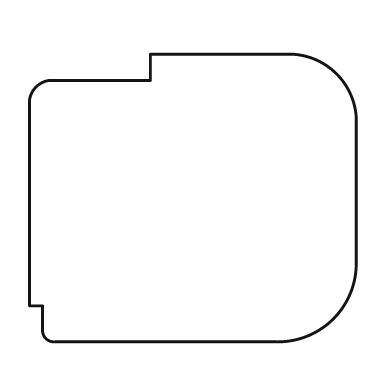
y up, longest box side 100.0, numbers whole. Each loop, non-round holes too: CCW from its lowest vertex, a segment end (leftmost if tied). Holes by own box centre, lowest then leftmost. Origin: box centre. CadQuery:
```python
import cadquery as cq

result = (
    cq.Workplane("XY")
    .moveTo(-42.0, -44.0)
    .lineTo(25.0, -44.0)
    .threePointArc((43.0, -37.0), (50.0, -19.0))
    .lineTo(50.0, 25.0)
    .threePointArc((44.0, 38.0), (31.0, 44.0))
    .lineTo(-13.0, 44.0)
    .lineTo(-13.0, 36.0)
    .lineTo(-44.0, 36.0)
    .threePointArc((-48.0, 34.0), (-50.0, 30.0))
    .lineTo(-50.0, -33.0)
    .lineTo(-46.0, -33.0)
    .lineTo(-46.0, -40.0)
    .threePointArc((-45.0, -43.0), (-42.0, -44.0))
    .close()
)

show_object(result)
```